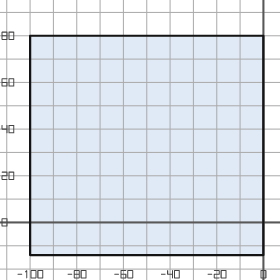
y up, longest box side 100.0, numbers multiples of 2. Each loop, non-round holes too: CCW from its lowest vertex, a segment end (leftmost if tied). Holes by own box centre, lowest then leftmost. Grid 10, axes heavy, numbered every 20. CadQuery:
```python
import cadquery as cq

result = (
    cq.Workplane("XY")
    .moveTo(-100.0, -14.0)
    .lineTo(0.0, -14.0)
    .lineTo(0.0, 80.0)
    .lineTo(-100.0, 80.0)
    .close()
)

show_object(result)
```